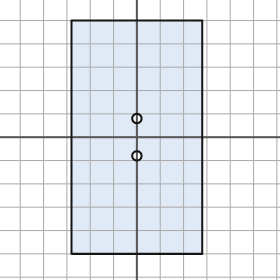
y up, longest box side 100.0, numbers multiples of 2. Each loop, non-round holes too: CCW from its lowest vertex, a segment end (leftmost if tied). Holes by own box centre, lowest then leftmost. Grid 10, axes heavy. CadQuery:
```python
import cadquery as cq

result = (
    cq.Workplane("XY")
    .moveTo(-28.0, -50.0)
    .lineTo(28.0, -50.0)
    .lineTo(28.0, 50.0)
    .lineTo(-28.0, 50.0)
    .close()
    .moveTo(0.0, -8.0)
    .circle(2.0)
    .moveTo(0.0, 8.0)
    .circle(2.0)
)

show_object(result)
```